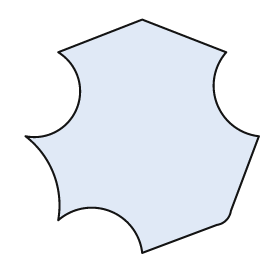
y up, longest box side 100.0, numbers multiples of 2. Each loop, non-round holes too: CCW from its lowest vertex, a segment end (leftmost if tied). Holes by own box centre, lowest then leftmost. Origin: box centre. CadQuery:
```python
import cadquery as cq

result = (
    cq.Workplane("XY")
    .moveTo(0.0, -50.0)
    .lineTo(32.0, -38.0)
    .threePointArc((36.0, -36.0), (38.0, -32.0))
    .lineTo(50.0, 0.0)
    .threePointArc((32.0, 14.0), (36.0, 36.0))
    .lineTo(0.0, 50.0)
    .lineTo(-36.0, 36.0)
    .threePointArc((-28.0, 12.0), (-50.0, 0.0))
    .threePointArc((-38.0, -16.0), (-36.0, -36.0))
    .threePointArc((-14.0, -32.0), (0.0, -50.0))
    .close()
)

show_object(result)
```